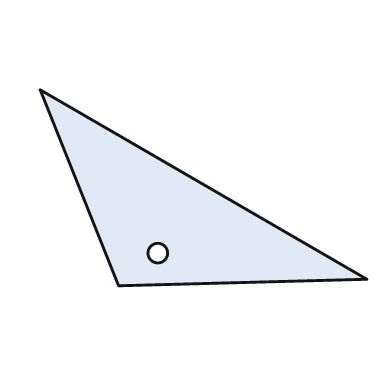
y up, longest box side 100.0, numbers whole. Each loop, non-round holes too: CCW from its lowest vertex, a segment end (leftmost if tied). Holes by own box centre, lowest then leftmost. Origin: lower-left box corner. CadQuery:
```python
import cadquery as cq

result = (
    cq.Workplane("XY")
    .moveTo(24.0, 0.0)
    .lineTo(100.0, 2.0)
    .lineTo(0.0, 60.0)
    .close()
    .moveTo(36.0, 10.0)
    .circle(3.0)
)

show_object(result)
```